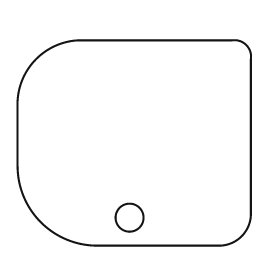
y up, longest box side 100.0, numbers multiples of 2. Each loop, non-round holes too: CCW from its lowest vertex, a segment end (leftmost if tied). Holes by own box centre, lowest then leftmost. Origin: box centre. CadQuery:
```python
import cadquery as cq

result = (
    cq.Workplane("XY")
    .moveTo(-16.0, -44.0)
    .lineTo(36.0, -44.0)
    .threePointArc((46.0, -40.0), (50.0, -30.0))
    .lineTo(50.0, 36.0)
    .threePointArc((48.0, 42.0), (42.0, 44.0))
    .lineTo(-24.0, 44.0)
    .threePointArc((-42.0, 36.0), (-50.0, 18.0))
    .lineTo(-50.0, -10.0)
    .threePointArc((-40.0, -34.0), (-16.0, -44.0))
    .close()
    .moveTo(-2.0, -32.0)
    .circle(6.0)
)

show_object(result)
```